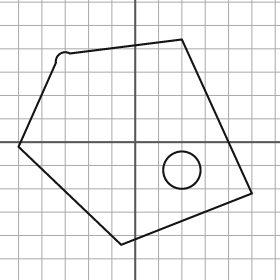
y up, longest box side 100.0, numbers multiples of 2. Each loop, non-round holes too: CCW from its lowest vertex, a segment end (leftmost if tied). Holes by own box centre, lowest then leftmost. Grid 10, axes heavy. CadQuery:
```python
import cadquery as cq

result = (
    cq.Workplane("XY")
    .moveTo(-6.0, -44.0)
    .lineTo(50.0, -22.0)
    .lineTo(20.0, 44.0)
    .lineTo(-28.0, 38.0)
    .threePointArc((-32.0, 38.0), (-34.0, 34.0))
    .lineTo(-50.0, -2.0)
    .close()
    .moveTo(20.0, -12.0)
    .circle(8.0)
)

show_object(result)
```